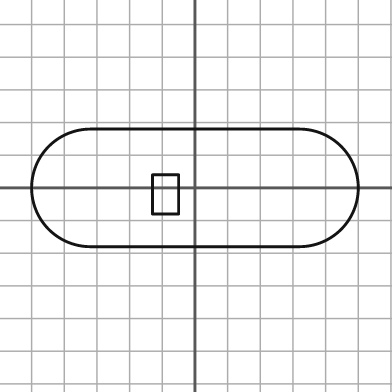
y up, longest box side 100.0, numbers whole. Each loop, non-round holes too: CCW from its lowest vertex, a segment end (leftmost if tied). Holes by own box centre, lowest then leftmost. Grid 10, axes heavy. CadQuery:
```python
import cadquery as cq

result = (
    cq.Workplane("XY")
    .moveTo(-32.0, -18.0)
    .lineTo(32.0, -18.0)
    .threePointArc((50.0, 0.0), (32.0, 18.0))
    .lineTo(-32.0, 18.0)
    .threePointArc((-50.0, 0.0), (-32.0, -18.0))
    .close()
    .moveTo(-13.0, -8.0)
    .lineTo(-5.0, -8.0)
    .lineTo(-5.0, 4.0)
    .lineTo(-13.0, 4.0)
    .close()
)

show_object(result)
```